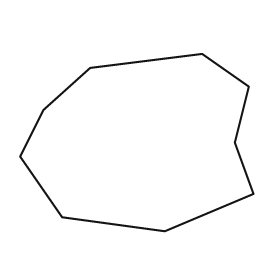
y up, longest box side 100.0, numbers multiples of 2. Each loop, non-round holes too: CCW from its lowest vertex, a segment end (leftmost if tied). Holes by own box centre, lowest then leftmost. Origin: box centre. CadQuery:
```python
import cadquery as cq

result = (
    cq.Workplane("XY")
    .moveTo(12.0, -38.0)
    .lineTo(50.0, -22.0)
    .lineTo(42.0, 0.0)
    .lineTo(48.0, 24.0)
    .lineTo(28.0, 38.0)
    .lineTo(-20.0, 32.0)
    .lineTo(-40.0, 14.0)
    .lineTo(-50.0, -6.0)
    .lineTo(-32.0, -32.0)
    .close()
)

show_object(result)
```